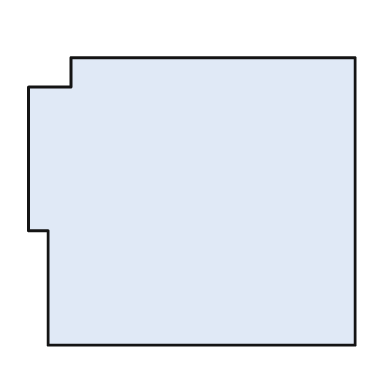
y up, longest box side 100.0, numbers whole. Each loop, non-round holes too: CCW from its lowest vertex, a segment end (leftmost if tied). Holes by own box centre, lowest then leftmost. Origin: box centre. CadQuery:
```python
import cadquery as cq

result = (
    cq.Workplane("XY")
    .moveTo(-44.0, -44.0)
    .lineTo(50.0, -44.0)
    .lineTo(50.0, 44.0)
    .lineTo(-37.0, 44.0)
    .lineTo(-37.0, 35.0)
    .lineTo(-50.0, 35.0)
    .lineTo(-50.0, -9.0)
    .lineTo(-44.0, -9.0)
    .close()
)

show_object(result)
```